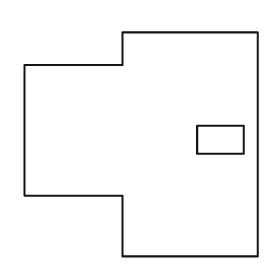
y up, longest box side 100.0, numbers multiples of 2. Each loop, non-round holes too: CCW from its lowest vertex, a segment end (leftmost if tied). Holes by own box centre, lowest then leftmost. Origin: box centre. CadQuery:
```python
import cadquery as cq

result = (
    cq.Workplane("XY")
    .moveTo(-8.0, -48.0)
    .lineTo(50.0, -48.0)
    .lineTo(50.0, 48.0)
    .lineTo(-8.0, 48.0)
    .lineTo(-8.0, 34.0)
    .lineTo(-50.0, 34.0)
    .lineTo(-50.0, -22.0)
    .lineTo(-8.0, -22.0)
    .close()
    .moveTo(24.0, -4.0)
    .lineTo(44.0, -4.0)
    .lineTo(44.0, 8.0)
    .lineTo(24.0, 8.0)
    .close()
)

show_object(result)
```